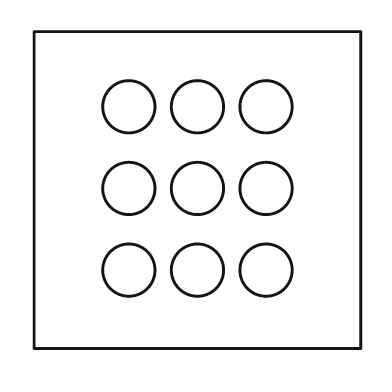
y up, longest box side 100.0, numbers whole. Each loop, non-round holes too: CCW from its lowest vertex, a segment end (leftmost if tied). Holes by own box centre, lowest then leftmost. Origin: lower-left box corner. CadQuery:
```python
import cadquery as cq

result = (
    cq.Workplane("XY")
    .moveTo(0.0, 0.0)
    .lineTo(100.0, 0.0)
    .lineTo(100.0, 97.0)
    .lineTo(0.0, 97.0)
    .close()
    .moveTo(29.0, 24.0)
    .circle(8.0)
    .moveTo(50.0, 24.0)
    .circle(8.0)
    .moveTo(71.0, 24.0)
    .circle(8.0)
    .moveTo(29.0, 49.0)
    .circle(8.0)
    .moveTo(50.0, 49.0)
    .circle(8.0)
    .moveTo(71.0, 49.0)
    .circle(8.0)
    .moveTo(29.0, 74.0)
    .circle(8.0)
    .moveTo(50.0, 74.0)
    .circle(8.0)
    .moveTo(71.0, 74.0)
    .circle(8.0)
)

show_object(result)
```